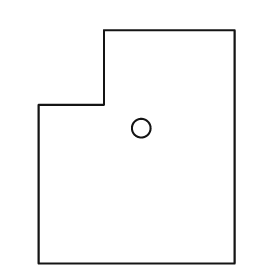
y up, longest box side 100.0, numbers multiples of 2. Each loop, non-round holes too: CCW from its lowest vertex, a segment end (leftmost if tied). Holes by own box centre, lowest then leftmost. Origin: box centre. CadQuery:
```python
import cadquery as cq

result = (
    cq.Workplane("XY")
    .moveTo(-42.0, -50.0)
    .lineTo(42.0, -50.0)
    .lineTo(42.0, 50.0)
    .lineTo(-14.0, 50.0)
    .lineTo(-14.0, 18.0)
    .lineTo(-42.0, 18.0)
    .close()
    .moveTo(2.0, 8.0)
    .circle(4.0)
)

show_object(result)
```